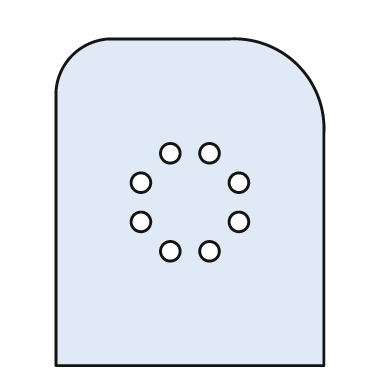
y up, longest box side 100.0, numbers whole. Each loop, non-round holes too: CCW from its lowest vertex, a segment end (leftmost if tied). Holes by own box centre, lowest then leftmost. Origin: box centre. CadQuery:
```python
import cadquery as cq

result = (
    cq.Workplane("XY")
    .moveTo(-41.0, -50.0)
    .lineTo(41.0, -50.0)
    .lineTo(41.0, 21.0)
    .threePointArc((33.0, 42.0), (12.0, 50.0))
    .lineTo(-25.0, 50.0)
    .threePointArc((-36.0, 45.0), (-41.0, 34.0))
    .close()
    .moveTo(-6.0, -15.0)
    .circle(3.0)
    .moveTo(6.0, -15.0)
    .circle(3.0)
    .moveTo(-15.0, -6.0)
    .circle(3.0)
    .moveTo(15.0, -6.0)
    .circle(3.0)
    .moveTo(-15.0, 6.0)
    .circle(3.0)
    .moveTo(15.0, 6.0)
    .circle(3.0)
    .moveTo(-6.0, 15.0)
    .circle(3.0)
    .moveTo(6.0, 15.0)
    .circle(3.0)
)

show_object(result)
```